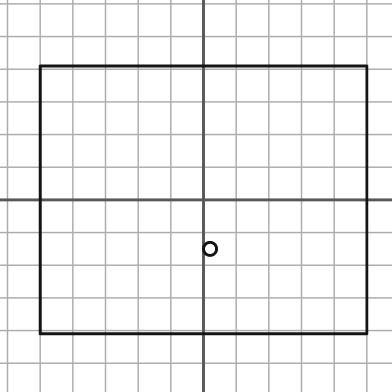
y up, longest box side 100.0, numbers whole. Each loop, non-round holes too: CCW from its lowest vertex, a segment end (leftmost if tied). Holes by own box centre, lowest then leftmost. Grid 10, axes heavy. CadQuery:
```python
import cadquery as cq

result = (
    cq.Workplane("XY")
    .moveTo(-50.0, -41.0)
    .lineTo(50.0, -41.0)
    .lineTo(50.0, 41.0)
    .lineTo(-50.0, 41.0)
    .close()
    .moveTo(2.0, -15.0)
    .circle(2.0)
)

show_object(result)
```